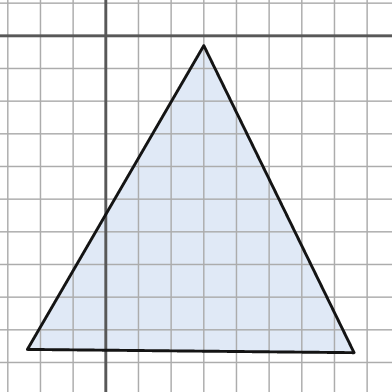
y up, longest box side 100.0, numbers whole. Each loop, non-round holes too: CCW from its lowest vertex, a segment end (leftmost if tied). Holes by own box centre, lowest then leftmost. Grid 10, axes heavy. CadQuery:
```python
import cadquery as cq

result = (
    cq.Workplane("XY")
    .moveTo(76.0, -97.0)
    .lineTo(30.0, -3.0)
    .lineTo(-24.0, -96.0)
    .close()
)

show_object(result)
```